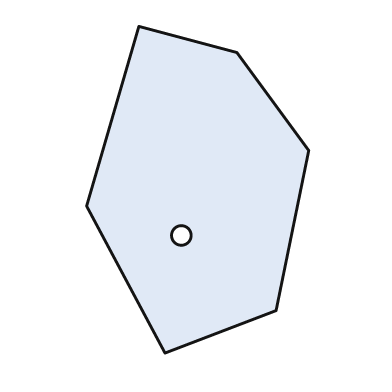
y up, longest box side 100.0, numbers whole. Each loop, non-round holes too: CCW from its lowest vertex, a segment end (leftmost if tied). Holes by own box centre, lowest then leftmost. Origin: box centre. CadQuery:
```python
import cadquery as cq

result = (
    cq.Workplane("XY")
    .moveTo(-10.0, -50.0)
    .lineTo(24.0, -37.0)
    .lineTo(34.0, 12.0)
    .lineTo(12.0, 42.0)
    .lineTo(-18.0, 50.0)
    .lineTo(-34.0, -5.0)
    .close()
    .moveTo(-5.0, -14.0)
    .circle(3.0)
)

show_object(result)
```